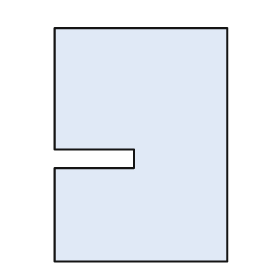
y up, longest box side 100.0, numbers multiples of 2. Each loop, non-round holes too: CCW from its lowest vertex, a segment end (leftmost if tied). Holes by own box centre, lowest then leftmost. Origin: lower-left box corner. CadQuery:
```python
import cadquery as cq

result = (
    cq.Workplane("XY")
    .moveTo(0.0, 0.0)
    .lineTo(74.0, 0.0)
    .lineTo(74.0, 100.0)
    .lineTo(0.0, 100.0)
    .lineTo(0.0, 48.0)
    .lineTo(34.0, 48.0)
    .lineTo(34.0, 40.0)
    .lineTo(0.0, 40.0)
    .close()
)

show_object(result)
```